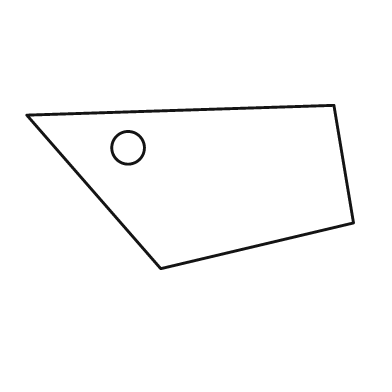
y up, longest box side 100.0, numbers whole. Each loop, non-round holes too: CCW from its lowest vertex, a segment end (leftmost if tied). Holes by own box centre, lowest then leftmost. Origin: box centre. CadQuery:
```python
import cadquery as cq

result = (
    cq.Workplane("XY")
    .moveTo(-9.0, -25.0)
    .lineTo(50.0, -11.0)
    .lineTo(44.0, 25.0)
    .lineTo(-50.0, 22.0)
    .close()
    .moveTo(-19.0, 12.0)
    .circle(5.0)
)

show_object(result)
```